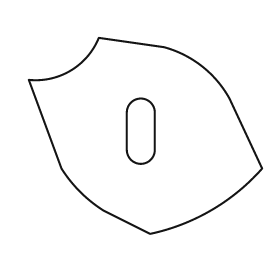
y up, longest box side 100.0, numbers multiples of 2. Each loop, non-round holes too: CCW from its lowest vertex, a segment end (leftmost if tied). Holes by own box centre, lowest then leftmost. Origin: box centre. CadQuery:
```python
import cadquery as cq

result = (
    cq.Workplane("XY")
    .moveTo(2.0, -42.0)
    .threePointArc((28.0, -32.0), (50.0, -14.0))
    .lineTo(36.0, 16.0)
    .threePointArc((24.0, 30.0), (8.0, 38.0))
    .lineTo(-20.0, 42.0)
    .threePointArc((-32.0, 28.0), (-50.0, 24.0))
    .lineTo(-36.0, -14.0)
    .threePointArc((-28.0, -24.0), (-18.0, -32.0))
    .close()
    .moveTo(-8.0, -6.0)
    .threePointArc((-2.0, -12.0), (4.0, -6.0))
    .lineTo(4.0, 10.0)
    .threePointArc((-2.0, 16.0), (-8.0, 10.0))
    .close()
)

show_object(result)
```